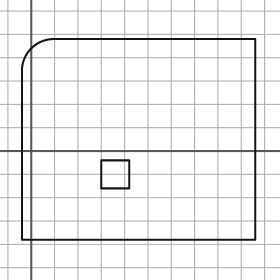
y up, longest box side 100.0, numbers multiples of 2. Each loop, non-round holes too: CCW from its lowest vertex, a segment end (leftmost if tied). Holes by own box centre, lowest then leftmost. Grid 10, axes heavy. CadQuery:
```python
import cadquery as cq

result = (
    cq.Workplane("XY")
    .moveTo(-4.0, -38.0)
    .lineTo(96.0, -38.0)
    .lineTo(96.0, 48.0)
    .lineTo(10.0, 48.0)
    .threePointArc((0.0, 44.0), (-4.0, 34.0))
    .close()
    .moveTo(30.0, -16.0)
    .lineTo(42.0, -16.0)
    .lineTo(42.0, -4.0)
    .lineTo(30.0, -4.0)
    .close()
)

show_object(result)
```